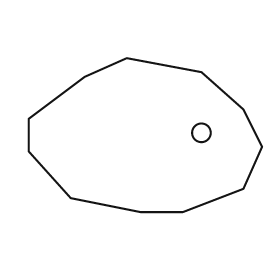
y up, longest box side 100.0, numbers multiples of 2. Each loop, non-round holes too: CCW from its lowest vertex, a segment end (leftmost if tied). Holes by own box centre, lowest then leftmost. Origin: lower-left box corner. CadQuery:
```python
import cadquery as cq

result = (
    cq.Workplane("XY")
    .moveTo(48.0, 0.0)
    .lineTo(66.0, 0.0)
    .lineTo(92.0, 10.0)
    .lineTo(100.0, 28.0)
    .lineTo(92.0, 44.0)
    .lineTo(74.0, 60.0)
    .lineTo(42.0, 66.0)
    .lineTo(24.0, 58.0)
    .lineTo(0.0, 40.0)
    .lineTo(0.0, 26.0)
    .lineTo(18.0, 6.0)
    .close()
    .moveTo(74.0, 34.0)
    .circle(4.0)
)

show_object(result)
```